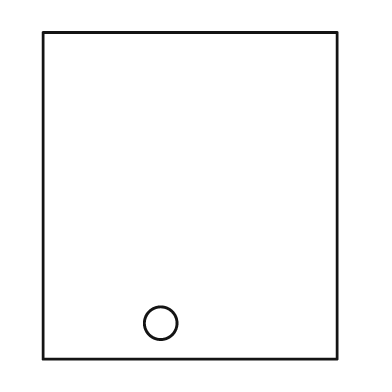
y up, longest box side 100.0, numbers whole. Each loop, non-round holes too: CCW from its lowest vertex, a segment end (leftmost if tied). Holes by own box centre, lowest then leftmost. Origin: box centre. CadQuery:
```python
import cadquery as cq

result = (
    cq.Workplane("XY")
    .moveTo(-45.0, -50.0)
    .lineTo(45.0, -50.0)
    .lineTo(45.0, 50.0)
    .lineTo(-45.0, 50.0)
    .close()
    .moveTo(-9.0, -39.0)
    .circle(5.0)
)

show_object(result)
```